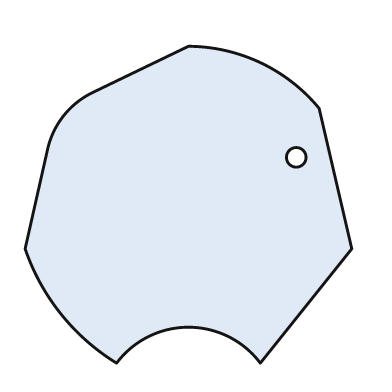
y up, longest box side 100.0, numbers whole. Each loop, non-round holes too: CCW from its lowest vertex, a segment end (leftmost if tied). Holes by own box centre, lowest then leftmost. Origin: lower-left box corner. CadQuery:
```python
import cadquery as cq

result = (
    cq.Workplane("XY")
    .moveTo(28.0, 0.0)
    .threePointArc((50.0, 11.0), (72.0, 0.0))
    .lineTo(100.0, 35.0)
    .lineTo(90.0, 78.0)
    .threePointArc((72.0, 92.0), (50.0, 97.0))
    .lineTo(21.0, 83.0)
    .threePointArc((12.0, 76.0), (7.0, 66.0))
    .lineTo(0.0, 35.0)
    .threePointArc((11.0, 15.0), (28.0, 0.0))
    .close()
    .moveTo(83.0, 63.0)
    .circle(3.0)
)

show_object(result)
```